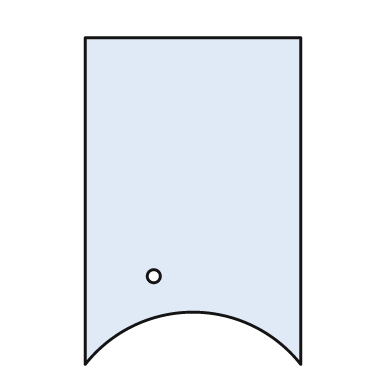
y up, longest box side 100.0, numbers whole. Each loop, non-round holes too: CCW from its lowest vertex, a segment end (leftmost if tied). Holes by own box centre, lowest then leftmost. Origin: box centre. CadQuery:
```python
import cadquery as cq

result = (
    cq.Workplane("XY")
    .moveTo(-33.0, -50.0)
    .threePointArc((0.0, -34.0), (33.0, -50.0))
    .lineTo(33.0, 50.0)
    .lineTo(-33.0, 50.0)
    .close()
    .moveTo(-12.0, -23.0)
    .circle(2.0)
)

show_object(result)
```